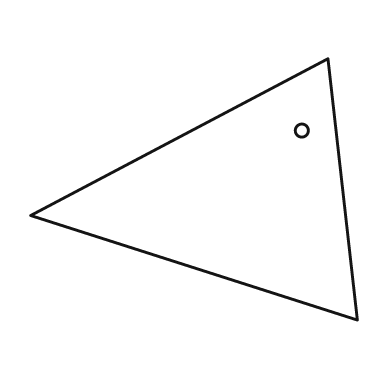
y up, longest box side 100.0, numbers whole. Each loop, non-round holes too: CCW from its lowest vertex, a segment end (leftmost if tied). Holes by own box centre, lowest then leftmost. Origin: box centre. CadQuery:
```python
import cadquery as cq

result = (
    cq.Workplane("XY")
    .moveTo(50.0, -40.0)
    .lineTo(41.0, 40.0)
    .lineTo(-50.0, -8.0)
    .close()
    .moveTo(33.0, 18.0)
    .circle(2.0)
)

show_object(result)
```